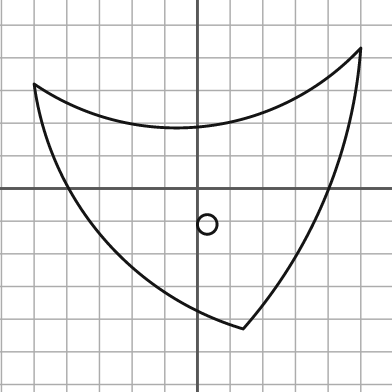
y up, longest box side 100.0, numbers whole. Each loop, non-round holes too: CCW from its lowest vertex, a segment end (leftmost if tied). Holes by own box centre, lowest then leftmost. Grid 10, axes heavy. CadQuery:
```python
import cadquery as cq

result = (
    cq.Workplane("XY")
    .moveTo(14.0, -43.0)
    .threePointArc((39.0, -3.0), (50.0, 43.0))
    .threePointArc((2.0, 19.0), (-50.0, 32.0))
    .threePointArc((-29.0, -15.0), (14.0, -43.0))
    .close()
    .moveTo(3.0, -11.0)
    .circle(3.0)
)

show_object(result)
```